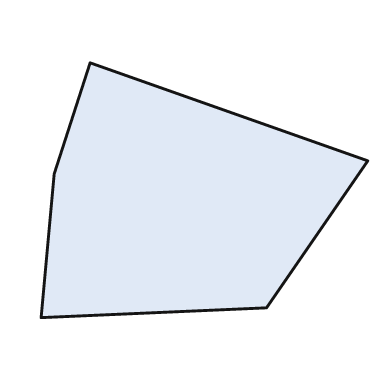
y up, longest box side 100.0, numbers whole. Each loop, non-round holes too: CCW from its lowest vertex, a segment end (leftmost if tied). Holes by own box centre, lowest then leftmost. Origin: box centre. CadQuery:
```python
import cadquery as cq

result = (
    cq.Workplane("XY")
    .moveTo(-50.0, -39.0)
    .lineTo(19.0, -36.0)
    .lineTo(50.0, 9.0)
    .lineTo(-35.0, 39.0)
    .lineTo(-46.0, 5.0)
    .close()
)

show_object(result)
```